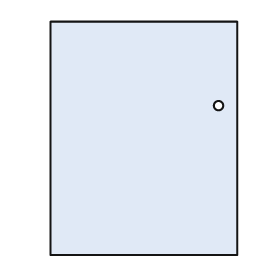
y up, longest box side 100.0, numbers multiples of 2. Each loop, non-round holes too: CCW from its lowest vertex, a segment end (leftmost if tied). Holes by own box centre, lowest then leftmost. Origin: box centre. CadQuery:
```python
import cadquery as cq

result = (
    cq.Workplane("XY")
    .moveTo(-40.0, -50.0)
    .lineTo(40.0, -50.0)
    .lineTo(40.0, 50.0)
    .lineTo(-40.0, 50.0)
    .close()
    .moveTo(32.0, 14.0)
    .circle(2.0)
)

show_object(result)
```